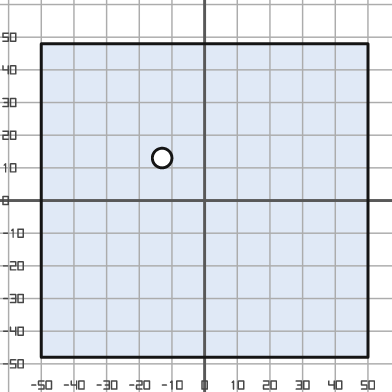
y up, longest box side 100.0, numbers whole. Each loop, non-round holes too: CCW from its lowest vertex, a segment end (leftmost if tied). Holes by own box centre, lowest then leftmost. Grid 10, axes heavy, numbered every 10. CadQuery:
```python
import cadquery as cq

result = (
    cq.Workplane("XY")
    .moveTo(-50.0, -48.0)
    .lineTo(50.0, -48.0)
    .lineTo(50.0, 48.0)
    .lineTo(-50.0, 48.0)
    .close()
    .moveTo(-13.0, 13.0)
    .circle(3.0)
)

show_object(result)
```